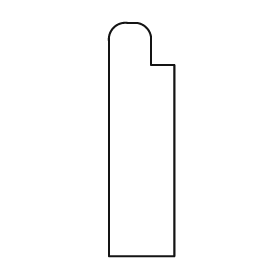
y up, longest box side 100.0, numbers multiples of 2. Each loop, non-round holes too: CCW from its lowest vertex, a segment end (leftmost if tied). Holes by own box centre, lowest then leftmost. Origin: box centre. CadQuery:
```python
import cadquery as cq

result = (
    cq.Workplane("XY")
    .moveTo(-14.0, -50.0)
    .lineTo(14.0, -50.0)
    .lineTo(14.0, 32.0)
    .lineTo(4.0, 32.0)
    .lineTo(4.0, 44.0)
    .threePointArc((2.0, 48.0), (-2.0, 50.0))
    .lineTo(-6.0, 50.0)
    .threePointArc((-12.0, 48.0), (-14.0, 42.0))
    .close()
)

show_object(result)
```